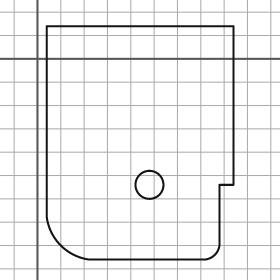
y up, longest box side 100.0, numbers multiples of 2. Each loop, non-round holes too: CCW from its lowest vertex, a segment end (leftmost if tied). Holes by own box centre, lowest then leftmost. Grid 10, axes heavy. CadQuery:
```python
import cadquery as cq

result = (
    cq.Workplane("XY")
    .moveTo(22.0, -86.0)
    .lineTo(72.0, -86.0)
    .threePointArc((76.0, -84.0), (78.0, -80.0))
    .lineTo(78.0, -54.0)
    .lineTo(84.0, -54.0)
    .lineTo(84.0, 14.0)
    .lineTo(4.0, 14.0)
    .lineTo(4.0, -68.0)
    .threePointArc((10.0, -80.0), (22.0, -86.0))
    .close()
    .moveTo(48.0, -54.0)
    .circle(6.0)
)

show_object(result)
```